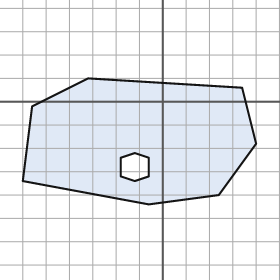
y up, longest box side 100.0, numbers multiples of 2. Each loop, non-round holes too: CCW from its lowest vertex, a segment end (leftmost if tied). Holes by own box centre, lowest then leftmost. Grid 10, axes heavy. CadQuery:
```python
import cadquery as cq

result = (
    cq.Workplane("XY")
    .moveTo(-6.0, -44.0)
    .lineTo(24.0, -40.0)
    .lineTo(40.0, -18.0)
    .lineTo(34.0, 6.0)
    .lineTo(-32.0, 10.0)
    .lineTo(-56.0, -2.0)
    .lineTo(-60.0, -34.0)
    .close()
    .moveTo(-12.0, -34.0)
    .lineTo(-6.0, -32.0)
    .lineTo(-6.0, -24.0)
    .lineTo(-12.0, -22.0)
    .lineTo(-18.0, -24.0)
    .lineTo(-18.0, -32.0)
    .close()
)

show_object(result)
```